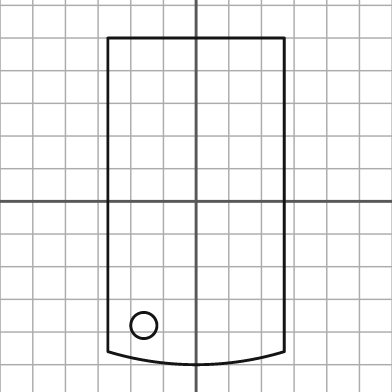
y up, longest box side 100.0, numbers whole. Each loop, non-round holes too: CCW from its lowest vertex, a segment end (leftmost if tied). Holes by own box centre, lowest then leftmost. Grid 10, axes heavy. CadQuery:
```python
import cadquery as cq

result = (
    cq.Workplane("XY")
    .moveTo(-27.0, -46.0)
    .threePointArc((0.0, -50.0), (27.0, -46.0))
    .lineTo(27.0, 50.0)
    .lineTo(-27.0, 50.0)
    .close()
    .moveTo(-16.0, -38.0)
    .circle(4.0)
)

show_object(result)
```